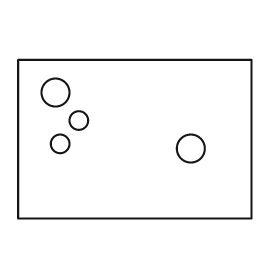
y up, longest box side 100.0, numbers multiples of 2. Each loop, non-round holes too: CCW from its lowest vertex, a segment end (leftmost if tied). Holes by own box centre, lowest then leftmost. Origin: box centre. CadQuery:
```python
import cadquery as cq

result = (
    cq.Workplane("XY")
    .moveTo(-50.0, -34.0)
    .lineTo(50.0, -34.0)
    .lineTo(50.0, 34.0)
    .lineTo(-50.0, 34.0)
    .close()
    .moveTo(24.0, -4.0)
    .circle(6.0)
    .moveTo(-32.0, -2.0)
    .circle(4.0)
    .moveTo(-24.0, 8.0)
    .circle(4.0)
    .moveTo(-34.0, 20.0)
    .circle(6.0)
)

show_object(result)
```